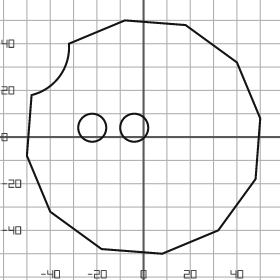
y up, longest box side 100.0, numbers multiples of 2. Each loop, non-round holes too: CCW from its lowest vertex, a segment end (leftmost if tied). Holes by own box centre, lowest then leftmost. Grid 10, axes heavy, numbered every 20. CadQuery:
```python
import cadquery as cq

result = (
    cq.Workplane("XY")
    .moveTo(8.0, -50.0)
    .lineTo(32.0, -40.0)
    .lineTo(48.0, -18.0)
    .lineTo(50.0, 8.0)
    .lineTo(40.0, 32.0)
    .lineTo(18.0, 48.0)
    .lineTo(-8.0, 50.0)
    .lineTo(-32.0, 40.0)
    .threePointArc((-36.0, 26.0), (-48.0, 18.0))
    .lineTo(-50.0, -8.0)
    .lineTo(-40.0, -32.0)
    .lineTo(-18.0, -48.0)
    .close()
    .moveTo(-22.0, 4.0)
    .circle(6.0)
    .moveTo(-4.0, 4.0)
    .circle(6.0)
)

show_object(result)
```